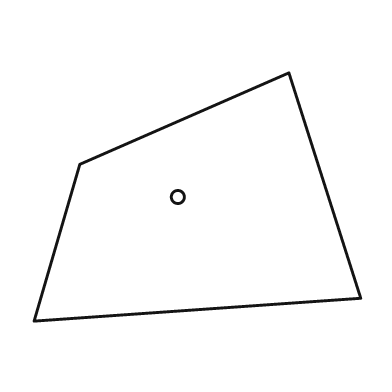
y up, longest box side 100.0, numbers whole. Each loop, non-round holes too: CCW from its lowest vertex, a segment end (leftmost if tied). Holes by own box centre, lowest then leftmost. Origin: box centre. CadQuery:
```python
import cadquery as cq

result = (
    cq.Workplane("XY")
    .moveTo(-50.0, -38.0)
    .lineTo(50.0, -31.0)
    .lineTo(28.0, 38.0)
    .lineTo(-36.0, 10.0)
    .close()
    .moveTo(-6.0, 0.0)
    .circle(2.0)
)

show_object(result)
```